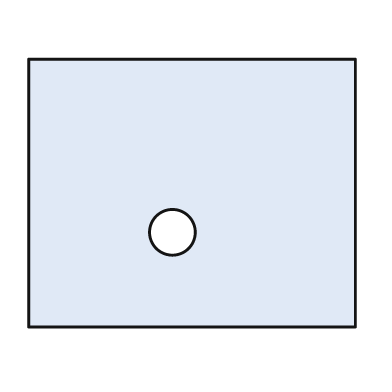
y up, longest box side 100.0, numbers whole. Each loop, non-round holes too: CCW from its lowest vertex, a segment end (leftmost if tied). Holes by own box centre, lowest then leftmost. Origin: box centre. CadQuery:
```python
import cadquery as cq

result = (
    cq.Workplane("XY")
    .moveTo(-50.0, -41.0)
    .lineTo(50.0, -41.0)
    .lineTo(50.0, 41.0)
    .lineTo(-50.0, 41.0)
    .close()
    .moveTo(-6.0, -12.0)
    .circle(7.0)
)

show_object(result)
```